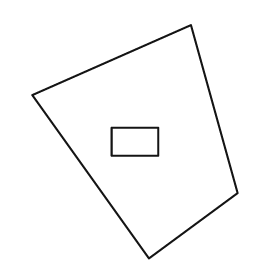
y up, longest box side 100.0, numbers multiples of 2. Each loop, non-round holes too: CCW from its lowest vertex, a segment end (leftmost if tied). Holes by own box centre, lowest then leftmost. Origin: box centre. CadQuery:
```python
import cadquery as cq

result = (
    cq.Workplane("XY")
    .moveTo(6.0, -50.0)
    .lineTo(44.0, -22.0)
    .lineTo(24.0, 50.0)
    .lineTo(-44.0, 20.0)
    .close()
    .moveTo(-10.0, -6.0)
    .lineTo(10.0, -6.0)
    .lineTo(10.0, 6.0)
    .lineTo(-10.0, 6.0)
    .close()
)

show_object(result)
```